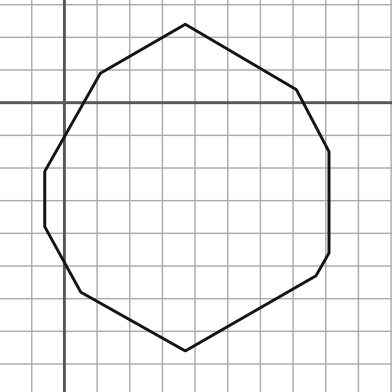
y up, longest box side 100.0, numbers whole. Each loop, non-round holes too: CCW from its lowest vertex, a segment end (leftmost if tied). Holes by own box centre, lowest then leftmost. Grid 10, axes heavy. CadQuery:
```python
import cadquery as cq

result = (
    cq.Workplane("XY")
    .moveTo(37.0, -76.0)
    .lineTo(77.0, -53.0)
    .lineTo(81.0, -46.0)
    .lineTo(81.0, -15.0)
    .lineTo(71.0, 4.0)
    .lineTo(37.0, 24.0)
    .lineTo(11.0, 9.0)
    .lineTo(-6.0, -21.0)
    .lineTo(-6.0, -38.0)
    .lineTo(5.0, -58.0)
    .close()
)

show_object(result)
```